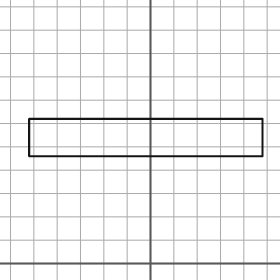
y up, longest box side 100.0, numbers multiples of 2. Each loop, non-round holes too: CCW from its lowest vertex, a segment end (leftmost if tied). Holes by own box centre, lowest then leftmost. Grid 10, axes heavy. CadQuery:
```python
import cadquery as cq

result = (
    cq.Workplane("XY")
    .moveTo(-52.0, 46.0)
    .lineTo(48.0, 46.0)
    .lineTo(48.0, 62.0)
    .lineTo(-52.0, 62.0)
    .close()
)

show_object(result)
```